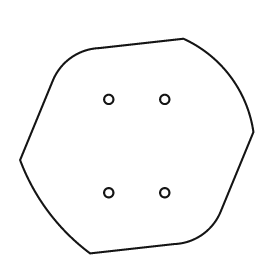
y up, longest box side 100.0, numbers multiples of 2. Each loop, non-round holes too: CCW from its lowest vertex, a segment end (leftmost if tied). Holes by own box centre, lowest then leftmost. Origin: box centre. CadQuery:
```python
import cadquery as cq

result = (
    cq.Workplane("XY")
    .moveTo(-20.0, -46.0)
    .lineTo(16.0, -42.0)
    .threePointArc((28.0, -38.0), (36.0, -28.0))
    .lineTo(50.0, 6.0)
    .threePointArc((40.0, 30.0), (20.0, 46.0))
    .lineTo(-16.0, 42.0)
    .threePointArc((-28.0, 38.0), (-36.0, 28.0))
    .lineTo(-50.0, -6.0)
    .threePointArc((-38.0, -28.0), (-20.0, -46.0))
    .close()
    .moveTo(-12.0, -20.0)
    .circle(2.0)
    .moveTo(12.0, -20.0)
    .circle(2.0)
    .moveTo(-12.0, 20.0)
    .circle(2.0)
    .moveTo(12.0, 20.0)
    .circle(2.0)
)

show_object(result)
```